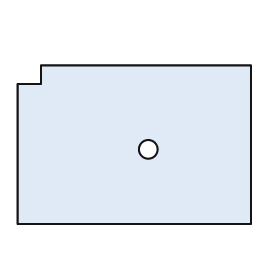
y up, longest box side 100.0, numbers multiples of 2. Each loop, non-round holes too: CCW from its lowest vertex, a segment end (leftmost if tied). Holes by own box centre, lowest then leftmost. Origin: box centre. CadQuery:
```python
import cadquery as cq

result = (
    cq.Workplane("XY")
    .moveTo(-50.0, -34.0)
    .lineTo(50.0, -34.0)
    .lineTo(50.0, 34.0)
    .lineTo(-40.0, 34.0)
    .lineTo(-40.0, 26.0)
    .lineTo(-50.0, 26.0)
    .close()
    .moveTo(6.0, -2.0)
    .circle(4.0)
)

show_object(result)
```